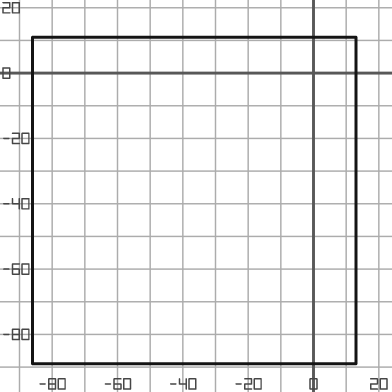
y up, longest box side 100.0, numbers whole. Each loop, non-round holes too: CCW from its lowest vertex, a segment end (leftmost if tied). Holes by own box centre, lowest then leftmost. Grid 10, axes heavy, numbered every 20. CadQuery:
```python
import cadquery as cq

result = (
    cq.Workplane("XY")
    .moveTo(-86.0, -89.0)
    .lineTo(13.0, -89.0)
    .lineTo(13.0, 11.0)
    .lineTo(-86.0, 11.0)
    .close()
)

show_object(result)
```